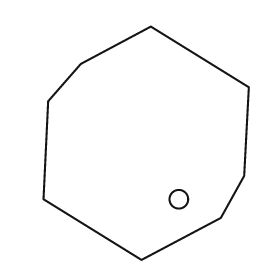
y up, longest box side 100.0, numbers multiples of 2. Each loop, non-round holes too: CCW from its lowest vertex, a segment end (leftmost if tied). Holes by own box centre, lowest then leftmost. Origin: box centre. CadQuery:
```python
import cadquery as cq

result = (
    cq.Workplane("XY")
    .moveTo(-2.0, -50.0)
    .lineTo(32.0, -32.0)
    .lineTo(42.0, -14.0)
    .lineTo(44.0, 24.0)
    .lineTo(2.0, 50.0)
    .lineTo(-28.0, 34.0)
    .lineTo(-42.0, 18.0)
    .lineTo(-44.0, -24.0)
    .close()
    .moveTo(14.0, -24.0)
    .circle(4.0)
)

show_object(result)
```